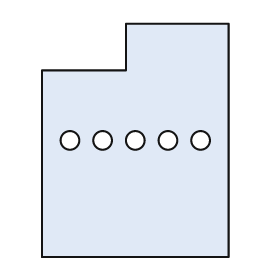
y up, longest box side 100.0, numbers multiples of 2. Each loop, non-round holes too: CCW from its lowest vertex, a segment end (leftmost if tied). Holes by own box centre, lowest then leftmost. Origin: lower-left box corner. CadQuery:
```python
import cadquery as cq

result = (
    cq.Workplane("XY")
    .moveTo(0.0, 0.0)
    .lineTo(80.0, 0.0)
    .lineTo(80.0, 100.0)
    .lineTo(36.0, 100.0)
    .lineTo(36.0, 80.0)
    .lineTo(0.0, 80.0)
    .close()
    .moveTo(12.0, 50.0)
    .circle(4.0)
    .moveTo(26.0, 50.0)
    .circle(4.0)
    .moveTo(40.0, 50.0)
    .circle(4.0)
    .moveTo(54.0, 50.0)
    .circle(4.0)
    .moveTo(68.0, 50.0)
    .circle(4.0)
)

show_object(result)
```